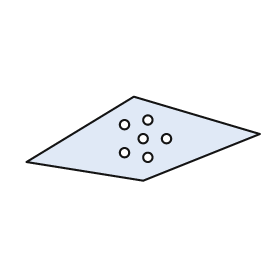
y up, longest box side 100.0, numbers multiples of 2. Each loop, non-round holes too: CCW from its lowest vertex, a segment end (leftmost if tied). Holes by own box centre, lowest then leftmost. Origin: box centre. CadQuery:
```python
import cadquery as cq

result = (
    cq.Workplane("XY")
    .moveTo(0.0, -18.0)
    .lineTo(50.0, 2.0)
    .lineTo(-4.0, 18.0)
    .lineTo(-50.0, -10.0)
    .close()
    .moveTo(2.0, -8.0)
    .circle(2.0)
    .moveTo(-8.0, -6.0)
    .circle(2.0)
    .moveTo(0.0, 0.0)
    .circle(2.0)
    .moveTo(10.0, 0.0)
    .circle(2.0)
    .moveTo(-8.0, 6.0)
    .circle(2.0)
    .moveTo(2.0, 8.0)
    .circle(2.0)
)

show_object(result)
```